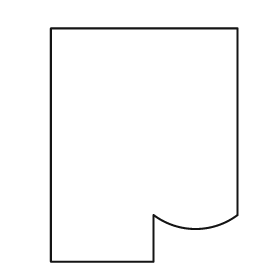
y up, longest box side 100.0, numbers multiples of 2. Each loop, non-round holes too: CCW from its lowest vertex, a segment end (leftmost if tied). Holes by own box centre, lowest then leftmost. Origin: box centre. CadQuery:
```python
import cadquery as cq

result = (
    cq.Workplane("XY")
    .moveTo(-40.0, -50.0)
    .lineTo(4.0, -50.0)
    .lineTo(4.0, -30.0)
    .threePointArc((22.0, -36.0), (40.0, -30.0))
    .lineTo(40.0, 50.0)
    .lineTo(-40.0, 50.0)
    .close()
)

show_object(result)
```